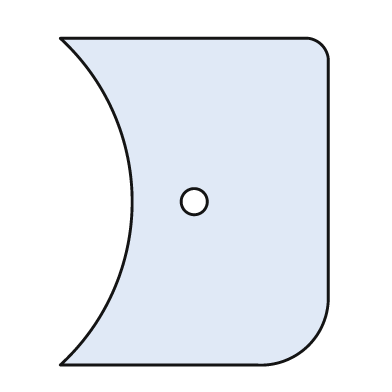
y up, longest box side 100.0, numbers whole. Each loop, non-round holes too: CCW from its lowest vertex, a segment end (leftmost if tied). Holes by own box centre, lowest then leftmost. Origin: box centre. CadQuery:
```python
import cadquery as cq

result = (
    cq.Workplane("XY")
    .moveTo(-41.0, -50.0)
    .lineTo(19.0, -50.0)
    .threePointArc((35.0, -44.0), (41.0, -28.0))
    .lineTo(41.0, 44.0)
    .threePointArc((39.0, 48.0), (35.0, 50.0))
    .lineTo(-41.0, 50.0)
    .threePointArc((-19.0, 0.0), (-41.0, -50.0))
    .close()
    .moveTo(0.0, 0.0)
    .circle(4.0)
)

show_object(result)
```